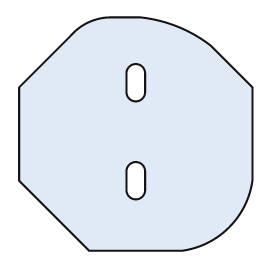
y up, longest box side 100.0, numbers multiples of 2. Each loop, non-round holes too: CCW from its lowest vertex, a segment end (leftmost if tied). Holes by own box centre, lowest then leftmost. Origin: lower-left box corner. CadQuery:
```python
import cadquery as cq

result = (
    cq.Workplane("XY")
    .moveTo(30.0, 0.0)
    .lineTo(70.0, 0.0)
    .threePointArc((90.0, 10.0), (100.0, 30.0))
    .lineTo(100.0, 70.0)
    .lineTo(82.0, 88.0)
    .threePointArc((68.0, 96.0), (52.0, 100.0))
    .lineTo(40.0, 100.0)
    .threePointArc((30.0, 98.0), (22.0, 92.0))
    .lineTo(0.0, 70.0)
    .lineTo(0.0, 30.0)
    .close()
    .moveTo(46.0, 26.0)
    .threePointArc((50.0, 22.0), (54.0, 26.0))
    .lineTo(54.0, 34.0)
    .threePointArc((50.0, 38.0), (46.0, 34.0))
    .close()
    .moveTo(46.0, 68.0)
    .threePointArc((50.0, 64.0), (54.0, 68.0))
    .lineTo(54.0, 76.0)
    .threePointArc((50.0, 80.0), (46.0, 76.0))
    .close()
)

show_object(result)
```